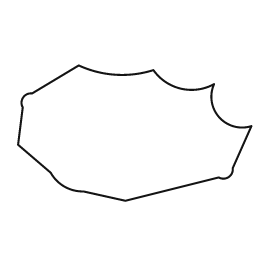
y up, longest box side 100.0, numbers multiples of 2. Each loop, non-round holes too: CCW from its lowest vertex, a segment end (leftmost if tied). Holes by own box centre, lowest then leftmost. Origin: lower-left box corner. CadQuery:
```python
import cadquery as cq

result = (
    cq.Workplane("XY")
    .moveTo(46.0, 0.0)
    .lineTo(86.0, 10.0)
    .threePointArc((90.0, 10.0), (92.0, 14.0))
    .lineTo(100.0, 32.0)
    .threePointArc((86.0, 36.0), (84.0, 50.0))
    .threePointArc((70.0, 48.0), (58.0, 56.0))
    .threePointArc((42.0, 54.0), (26.0, 58.0))
    .lineTo(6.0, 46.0)
    .threePointArc((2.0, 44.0), (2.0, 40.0))
    .lineTo(0.0, 24.0)
    .lineTo(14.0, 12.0)
    .threePointArc((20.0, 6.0), (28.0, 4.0))
    .close()
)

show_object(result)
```